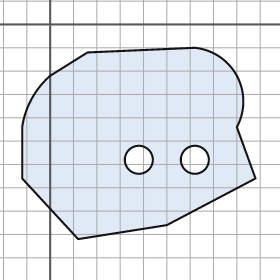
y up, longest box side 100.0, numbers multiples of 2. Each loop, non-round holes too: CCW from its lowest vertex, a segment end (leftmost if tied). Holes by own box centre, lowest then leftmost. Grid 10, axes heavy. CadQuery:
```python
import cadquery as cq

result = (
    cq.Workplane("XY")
    .moveTo(12.0, -92.0)
    .lineTo(50.0, -86.0)
    .lineTo(88.0, -66.0)
    .lineTo(80.0, -44.0)
    .threePointArc((80.0, -22.0), (62.0, -10.0))
    .lineTo(16.0, -12.0)
    .lineTo(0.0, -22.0)
    .threePointArc((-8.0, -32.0), (-12.0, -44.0))
    .lineTo(-12.0, -66.0)
    .close()
    .moveTo(38.0, -58.0)
    .circle(6.0)
    .moveTo(62.0, -58.0)
    .circle(6.0)
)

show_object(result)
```